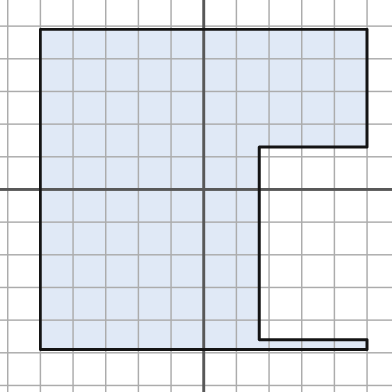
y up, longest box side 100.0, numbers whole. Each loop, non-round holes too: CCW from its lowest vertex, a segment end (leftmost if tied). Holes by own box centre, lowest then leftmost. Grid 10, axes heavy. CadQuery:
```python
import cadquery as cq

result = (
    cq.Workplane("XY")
    .moveTo(-50.0, -49.0)
    .lineTo(50.0, -49.0)
    .lineTo(50.0, -46.0)
    .lineTo(17.0, -46.0)
    .lineTo(17.0, 13.0)
    .lineTo(50.0, 13.0)
    .lineTo(50.0, 49.0)
    .lineTo(-50.0, 49.0)
    .close()
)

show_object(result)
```